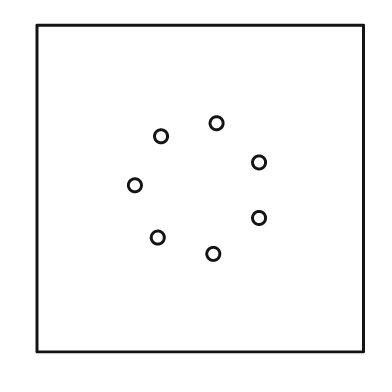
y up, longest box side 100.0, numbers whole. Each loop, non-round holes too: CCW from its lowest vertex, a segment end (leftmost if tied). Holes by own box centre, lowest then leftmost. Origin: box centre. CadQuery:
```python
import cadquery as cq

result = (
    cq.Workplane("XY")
    .moveTo(-50.0, -50.0)
    .lineTo(50.0, -50.0)
    .lineTo(50.0, 50.0)
    .lineTo(-50.0, 50.0)
    .close()
    .moveTo(4.0, -20.0)
    .circle(2.0)
    .moveTo(-13.0, -15.0)
    .circle(2.0)
    .moveTo(18.0, -9.0)
    .circle(2.0)
    .moveTo(-20.0, 1.0)
    .circle(2.0)
    .moveTo(18.0, 8.0)
    .circle(2.0)
    .moveTo(-12.0, 16.0)
    .circle(2.0)
    .moveTo(5.0, 20.0)
    .circle(2.0)
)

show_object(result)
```